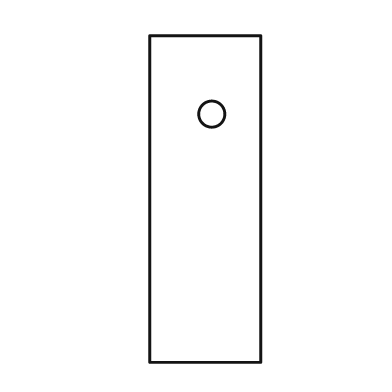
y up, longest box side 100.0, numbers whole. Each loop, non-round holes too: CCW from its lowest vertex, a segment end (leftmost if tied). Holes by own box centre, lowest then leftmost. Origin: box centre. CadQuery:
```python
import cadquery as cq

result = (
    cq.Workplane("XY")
    .moveTo(-17.0, -50.0)
    .lineTo(17.0, -50.0)
    .lineTo(17.0, 50.0)
    .lineTo(-17.0, 50.0)
    .close()
    .moveTo(2.0, 26.0)
    .circle(4.0)
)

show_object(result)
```